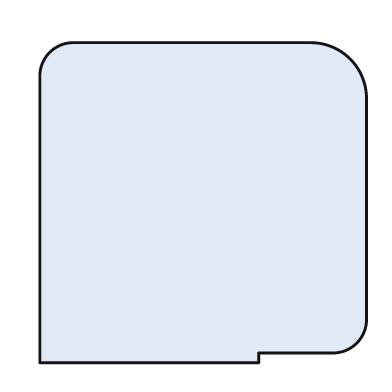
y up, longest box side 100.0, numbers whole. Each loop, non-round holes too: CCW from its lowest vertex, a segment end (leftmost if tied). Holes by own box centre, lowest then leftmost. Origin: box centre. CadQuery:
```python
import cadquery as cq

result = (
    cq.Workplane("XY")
    .moveTo(-50.0, -49.0)
    .lineTo(17.0, -49.0)
    .lineTo(17.0, -46.0)
    .lineTo(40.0, -46.0)
    .threePointArc((47.0, -43.0), (50.0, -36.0))
    .lineTo(50.0, 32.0)
    .threePointArc((45.0, 44.0), (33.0, 49.0))
    .lineTo(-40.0, 49.0)
    .threePointArc((-47.0, 46.0), (-50.0, 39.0))
    .close()
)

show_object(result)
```